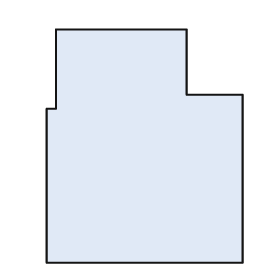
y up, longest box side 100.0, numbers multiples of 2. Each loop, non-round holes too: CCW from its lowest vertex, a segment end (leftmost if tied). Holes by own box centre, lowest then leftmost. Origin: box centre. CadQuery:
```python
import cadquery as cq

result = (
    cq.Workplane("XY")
    .moveTo(-42.0, -50.0)
    .lineTo(42.0, -50.0)
    .lineTo(42.0, 22.0)
    .lineTo(18.0, 22.0)
    .lineTo(18.0, 50.0)
    .lineTo(-38.0, 50.0)
    .lineTo(-38.0, 16.0)
    .lineTo(-42.0, 16.0)
    .close()
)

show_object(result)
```